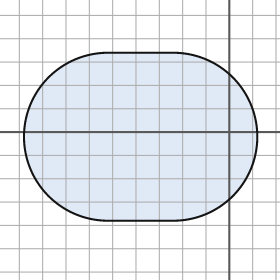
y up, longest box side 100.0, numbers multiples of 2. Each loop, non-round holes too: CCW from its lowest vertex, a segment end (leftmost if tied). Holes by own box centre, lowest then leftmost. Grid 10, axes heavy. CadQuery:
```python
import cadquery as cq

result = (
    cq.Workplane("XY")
    .moveTo(-52.0, -38.0)
    .lineTo(-24.0, -38.0)
    .threePointArc((12.0, -2.0), (-24.0, 34.0))
    .lineTo(-52.0, 34.0)
    .threePointArc((-88.0, -2.0), (-52.0, -38.0))
    .close()
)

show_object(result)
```